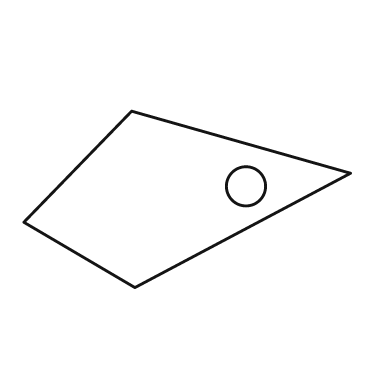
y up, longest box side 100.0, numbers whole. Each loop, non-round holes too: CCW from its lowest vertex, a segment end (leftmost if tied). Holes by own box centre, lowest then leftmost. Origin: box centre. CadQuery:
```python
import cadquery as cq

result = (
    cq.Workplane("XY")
    .moveTo(-16.0, -27.0)
    .lineTo(50.0, 8.0)
    .lineTo(-17.0, 27.0)
    .lineTo(-50.0, -7.0)
    .close()
    .moveTo(18.0, 4.0)
    .circle(6.0)
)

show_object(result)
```